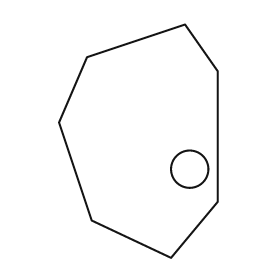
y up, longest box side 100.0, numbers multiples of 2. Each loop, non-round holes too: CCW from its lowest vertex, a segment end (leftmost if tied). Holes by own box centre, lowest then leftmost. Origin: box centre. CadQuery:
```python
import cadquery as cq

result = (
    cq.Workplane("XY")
    .moveTo(14.0, -50.0)
    .lineTo(34.0, -26.0)
    .lineTo(34.0, 30.0)
    .lineTo(20.0, 50.0)
    .lineTo(-22.0, 36.0)
    .lineTo(-34.0, 8.0)
    .lineTo(-20.0, -34.0)
    .close()
    .moveTo(22.0, -12.0)
    .circle(8.0)
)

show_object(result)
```